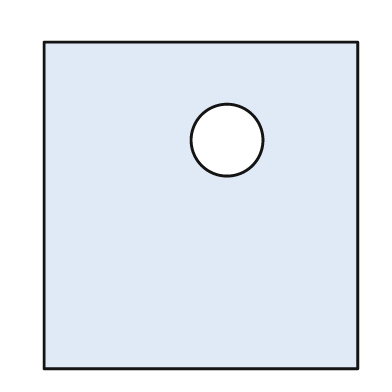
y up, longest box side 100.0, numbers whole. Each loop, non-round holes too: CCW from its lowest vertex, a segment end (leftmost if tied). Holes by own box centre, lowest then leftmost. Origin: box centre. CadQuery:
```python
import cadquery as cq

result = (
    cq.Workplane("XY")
    .moveTo(-48.0, -50.0)
    .lineTo(48.0, -50.0)
    .lineTo(48.0, 50.0)
    .lineTo(-48.0, 50.0)
    .close()
    .moveTo(8.0, 20.0)
    .circle(11.0)
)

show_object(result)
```